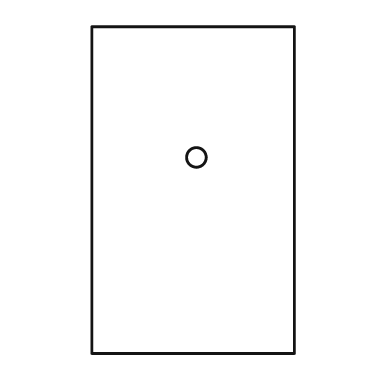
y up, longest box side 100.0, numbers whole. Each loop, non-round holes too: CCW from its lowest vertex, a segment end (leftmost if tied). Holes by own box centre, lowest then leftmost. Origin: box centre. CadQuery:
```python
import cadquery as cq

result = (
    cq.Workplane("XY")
    .moveTo(-31.0, -50.0)
    .lineTo(31.0, -50.0)
    .lineTo(31.0, 50.0)
    .lineTo(-31.0, 50.0)
    .close()
    .moveTo(1.0, 10.0)
    .circle(3.0)
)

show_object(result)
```